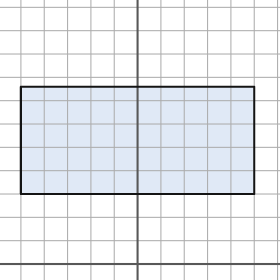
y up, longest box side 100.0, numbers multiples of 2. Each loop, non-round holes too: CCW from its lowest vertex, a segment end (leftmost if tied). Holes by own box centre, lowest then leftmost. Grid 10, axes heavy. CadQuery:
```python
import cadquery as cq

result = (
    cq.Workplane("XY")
    .moveTo(-50.0, 30.0)
    .lineTo(50.0, 30.0)
    .lineTo(50.0, 76.0)
    .lineTo(-50.0, 76.0)
    .close()
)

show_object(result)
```